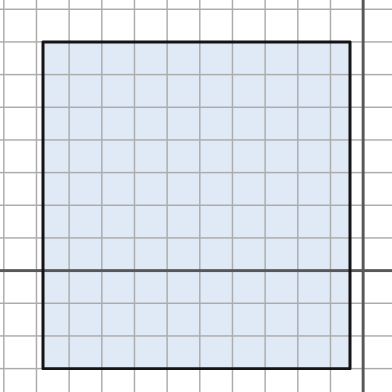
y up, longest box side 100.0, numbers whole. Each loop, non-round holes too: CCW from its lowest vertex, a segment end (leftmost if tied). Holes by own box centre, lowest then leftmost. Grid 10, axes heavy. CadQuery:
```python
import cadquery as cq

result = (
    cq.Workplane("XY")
    .moveTo(-98.0, -30.0)
    .lineTo(-4.0, -30.0)
    .lineTo(-4.0, 70.0)
    .lineTo(-98.0, 70.0)
    .close()
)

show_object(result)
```